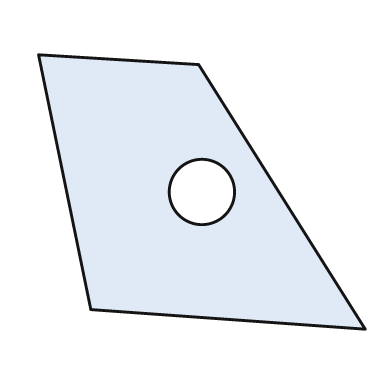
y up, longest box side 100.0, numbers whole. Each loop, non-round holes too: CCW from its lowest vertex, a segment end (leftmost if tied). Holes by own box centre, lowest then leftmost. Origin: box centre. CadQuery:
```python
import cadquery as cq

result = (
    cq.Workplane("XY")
    .moveTo(50.0, -42.0)
    .lineTo(-1.0, 39.0)
    .lineTo(-50.0, 42.0)
    .lineTo(-34.0, -36.0)
    .close()
    .moveTo(0.0, 0.0)
    .circle(10.0)
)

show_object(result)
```